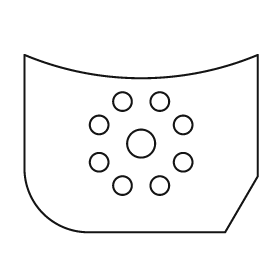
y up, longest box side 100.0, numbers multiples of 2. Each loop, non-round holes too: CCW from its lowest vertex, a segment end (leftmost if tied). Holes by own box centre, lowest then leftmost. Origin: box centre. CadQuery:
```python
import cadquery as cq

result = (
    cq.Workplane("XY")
    .moveTo(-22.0, -38.0)
    .lineTo(36.0, -38.0)
    .lineTo(50.0, -14.0)
    .lineTo(50.0, 38.0)
    .threePointArc((0.0, 28.0), (-50.0, 38.0))
    .lineTo(-50.0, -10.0)
    .threePointArc((-42.0, -30.0), (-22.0, -38.0))
    .close()
    .moveTo(-8.0, -18.0)
    .circle(4.0)
    .moveTo(8.0, -18.0)
    .circle(4.0)
    .moveTo(-18.0, -8.0)
    .circle(4.0)
    .moveTo(18.0, -8.0)
    .circle(4.0)
    .moveTo(0.0, 0.0)
    .circle(6.0)
    .moveTo(-18.0, 8.0)
    .circle(4.0)
    .moveTo(18.0, 8.0)
    .circle(4.0)
    .moveTo(-8.0, 18.0)
    .circle(4.0)
    .moveTo(8.0, 18.0)
    .circle(4.0)
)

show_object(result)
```